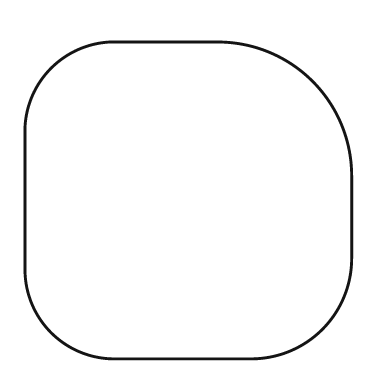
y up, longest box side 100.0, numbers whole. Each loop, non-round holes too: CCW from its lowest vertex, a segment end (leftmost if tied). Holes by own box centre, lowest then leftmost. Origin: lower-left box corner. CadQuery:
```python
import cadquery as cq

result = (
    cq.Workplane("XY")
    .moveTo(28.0, 0.0)
    .lineTo(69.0, 0.0)
    .threePointArc((91.0, 9.0), (100.0, 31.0))
    .lineTo(100.0, 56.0)
    .threePointArc((88.0, 85.0), (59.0, 97.0))
    .lineTo(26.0, 97.0)
    .threePointArc((8.0, 89.0), (0.0, 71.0))
    .lineTo(0.0, 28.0)
    .threePointArc((8.0, 8.0), (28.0, 0.0))
    .close()
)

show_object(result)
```